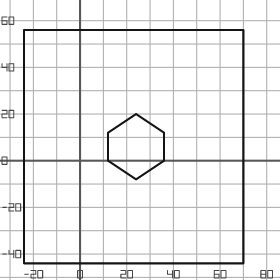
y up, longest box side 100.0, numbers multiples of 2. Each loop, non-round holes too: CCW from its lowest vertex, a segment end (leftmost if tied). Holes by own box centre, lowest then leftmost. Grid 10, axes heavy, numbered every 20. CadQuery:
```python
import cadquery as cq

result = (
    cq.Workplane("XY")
    .moveTo(-24.0, -44.0)
    .lineTo(70.0, -44.0)
    .lineTo(70.0, 56.0)
    .lineTo(-24.0, 56.0)
    .close()
    .moveTo(24.0, -8.0)
    .lineTo(36.0, 0.0)
    .lineTo(36.0, 12.0)
    .lineTo(24.0, 20.0)
    .lineTo(12.0, 12.0)
    .lineTo(12.0, 0.0)
    .close()
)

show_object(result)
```